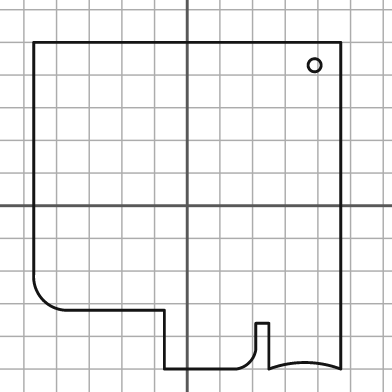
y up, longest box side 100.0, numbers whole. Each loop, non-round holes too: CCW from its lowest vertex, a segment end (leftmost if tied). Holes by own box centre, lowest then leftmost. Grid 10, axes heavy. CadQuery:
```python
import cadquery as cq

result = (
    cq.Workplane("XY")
    .moveTo(-7.0, -50.0)
    .lineTo(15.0, -50.0)
    .threePointArc((19.0, -48.0), (21.0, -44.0))
    .lineTo(21.0, -36.0)
    .lineTo(25.0, -36.0)
    .lineTo(25.0, -50.0)
    .threePointArc((36.0, -48.0), (47.0, -50.0))
    .lineTo(47.0, 50.0)
    .lineTo(-47.0, 50.0)
    .lineTo(-47.0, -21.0)
    .threePointArc((-44.0, -29.0), (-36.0, -32.0))
    .lineTo(-7.0, -32.0)
    .close()
    .moveTo(39.0, 43.0)
    .circle(2.0)
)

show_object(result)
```